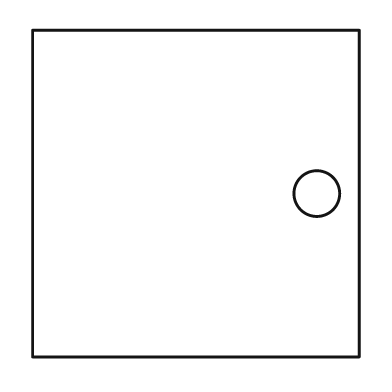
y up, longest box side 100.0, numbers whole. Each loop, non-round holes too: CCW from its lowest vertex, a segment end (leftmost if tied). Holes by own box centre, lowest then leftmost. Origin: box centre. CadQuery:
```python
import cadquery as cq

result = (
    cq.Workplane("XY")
    .moveTo(-50.0, -50.0)
    .lineTo(50.0, -50.0)
    .lineTo(50.0, 50.0)
    .lineTo(-50.0, 50.0)
    .close()
    .moveTo(37.0, 0.0)
    .circle(7.0)
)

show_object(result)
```